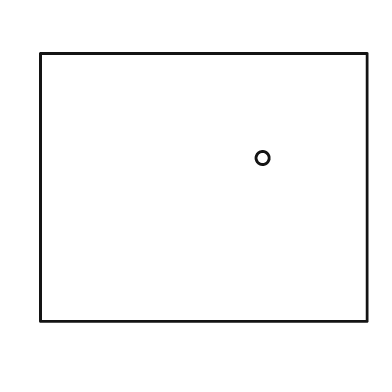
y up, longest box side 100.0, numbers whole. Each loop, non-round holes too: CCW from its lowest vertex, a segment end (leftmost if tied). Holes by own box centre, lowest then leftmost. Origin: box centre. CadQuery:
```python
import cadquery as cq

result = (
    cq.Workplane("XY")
    .moveTo(-50.0, -41.0)
    .lineTo(50.0, -41.0)
    .lineTo(50.0, 41.0)
    .lineTo(-50.0, 41.0)
    .close()
    .moveTo(18.0, 9.0)
    .circle(2.0)
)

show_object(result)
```